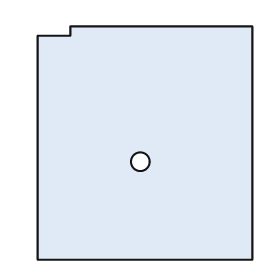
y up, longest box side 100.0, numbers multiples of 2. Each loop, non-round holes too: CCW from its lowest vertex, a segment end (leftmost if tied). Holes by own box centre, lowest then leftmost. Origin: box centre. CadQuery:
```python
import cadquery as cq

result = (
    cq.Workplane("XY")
    .moveTo(-46.0, -50.0)
    .lineTo(46.0, -50.0)
    .lineTo(46.0, 50.0)
    .lineTo(-32.0, 50.0)
    .lineTo(-32.0, 46.0)
    .lineTo(-46.0, 46.0)
    .close()
    .moveTo(-2.0, -8.0)
    .circle(4.0)
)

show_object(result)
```